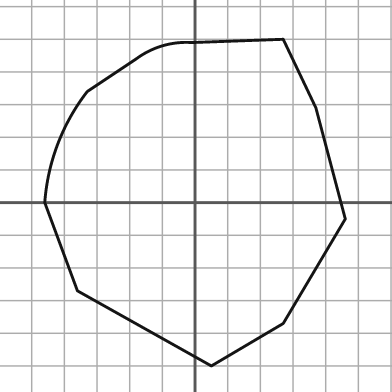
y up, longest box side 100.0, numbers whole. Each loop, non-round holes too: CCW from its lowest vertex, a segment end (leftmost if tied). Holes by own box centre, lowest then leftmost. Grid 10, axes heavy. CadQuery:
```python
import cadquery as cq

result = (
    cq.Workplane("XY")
    .moveTo(5.0, -50.0)
    .lineTo(27.0, -37.0)
    .lineTo(46.0, -5.0)
    .lineTo(37.0, 29.0)
    .lineTo(27.0, 50.0)
    .lineTo(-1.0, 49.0)
    .threePointArc((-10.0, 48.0), (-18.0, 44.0))
    .lineTo(-33.0, 34.0)
    .threePointArc((-42.0, 18.0), (-46.0, 0.0))
    .lineTo(-36.0, -27.0)
    .close()
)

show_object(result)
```